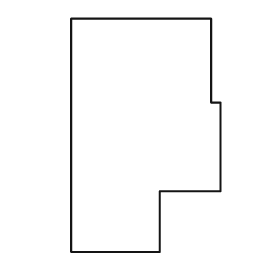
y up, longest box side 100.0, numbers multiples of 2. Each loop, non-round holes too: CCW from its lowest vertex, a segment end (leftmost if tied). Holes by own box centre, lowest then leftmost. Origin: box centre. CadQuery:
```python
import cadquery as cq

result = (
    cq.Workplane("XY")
    .moveTo(-32.0, -50.0)
    .lineTo(6.0, -50.0)
    .lineTo(6.0, -24.0)
    .lineTo(32.0, -24.0)
    .lineTo(32.0, 14.0)
    .lineTo(28.0, 14.0)
    .lineTo(28.0, 50.0)
    .lineTo(-32.0, 50.0)
    .close()
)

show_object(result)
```